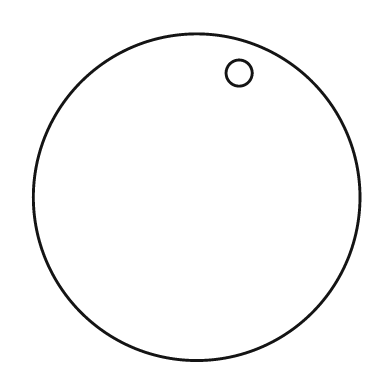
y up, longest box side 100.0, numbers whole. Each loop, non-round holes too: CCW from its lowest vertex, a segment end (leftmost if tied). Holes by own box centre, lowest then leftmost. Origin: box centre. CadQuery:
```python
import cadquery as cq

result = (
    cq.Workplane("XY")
    .moveTo(0.0, 0.0)
    .circle(50.0)
    .moveTo(13.0, 38.0)
    .circle(4.0)
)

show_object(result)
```